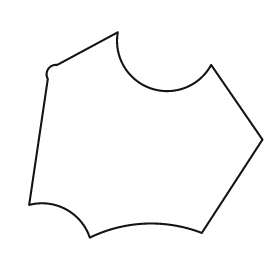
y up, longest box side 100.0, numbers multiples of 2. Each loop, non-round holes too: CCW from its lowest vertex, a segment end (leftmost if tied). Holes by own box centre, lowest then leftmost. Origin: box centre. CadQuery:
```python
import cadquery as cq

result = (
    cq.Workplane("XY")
    .moveTo(-24.0, -44.0)
    .threePointArc((0.0, -38.0), (24.0, -42.0))
    .lineTo(50.0, -2.0)
    .lineTo(28.0, 30.0)
    .threePointArc((2.0, 20.0), (-12.0, 44.0))
    .lineTo(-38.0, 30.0)
    .threePointArc((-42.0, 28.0), (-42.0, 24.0))
    .lineTo(-50.0, -30.0)
    .threePointArc((-34.0, -32.0), (-24.0, -44.0))
    .close()
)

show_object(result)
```